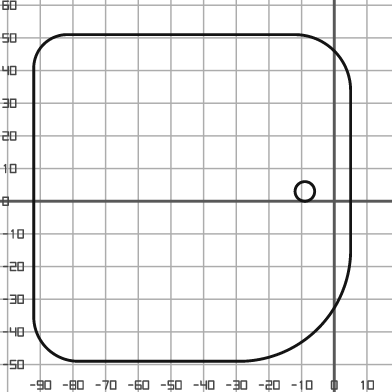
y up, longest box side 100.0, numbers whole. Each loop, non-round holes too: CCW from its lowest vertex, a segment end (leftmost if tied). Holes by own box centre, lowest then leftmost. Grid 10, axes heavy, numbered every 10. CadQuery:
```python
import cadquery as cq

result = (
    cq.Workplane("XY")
    .moveTo(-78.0, -49.0)
    .lineTo(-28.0, -49.0)
    .threePointArc((-5.0, -39.0), (5.0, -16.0))
    .lineTo(5.0, 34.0)
    .threePointArc((0.0, 46.0), (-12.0, 51.0))
    .lineTo(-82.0, 51.0)
    .threePointArc((-89.0, 48.0), (-92.0, 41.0))
    .lineTo(-92.0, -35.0)
    .threePointArc((-88.0, -45.0), (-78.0, -49.0))
    .close()
    .moveTo(-9.0, 3.0)
    .circle(3.0)
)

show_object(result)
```